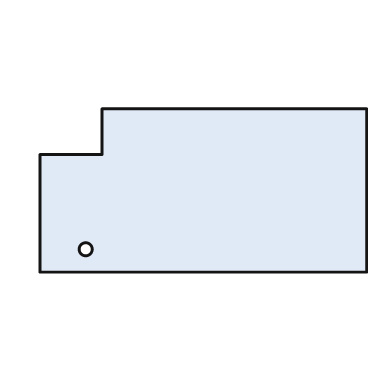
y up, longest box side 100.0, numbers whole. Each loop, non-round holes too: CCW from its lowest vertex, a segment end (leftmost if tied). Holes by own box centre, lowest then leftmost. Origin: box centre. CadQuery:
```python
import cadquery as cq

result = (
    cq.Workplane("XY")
    .moveTo(-50.0, -25.0)
    .lineTo(50.0, -25.0)
    .lineTo(50.0, 25.0)
    .lineTo(-31.0, 25.0)
    .lineTo(-31.0, 11.0)
    .lineTo(-50.0, 11.0)
    .close()
    .moveTo(-36.0, -18.0)
    .circle(2.0)
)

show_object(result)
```